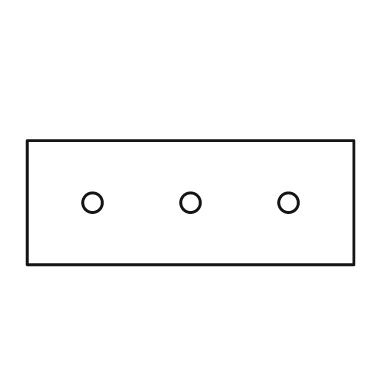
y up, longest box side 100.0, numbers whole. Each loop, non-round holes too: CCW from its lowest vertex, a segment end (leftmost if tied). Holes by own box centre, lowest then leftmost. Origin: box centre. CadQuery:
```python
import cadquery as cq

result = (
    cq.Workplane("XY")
    .moveTo(-50.0, -19.0)
    .lineTo(50.0, -19.0)
    .lineTo(50.0, 19.0)
    .lineTo(-50.0, 19.0)
    .close()
    .moveTo(-30.0, 0.0)
    .circle(3.0)
    .moveTo(0.0, 0.0)
    .circle(3.0)
    .moveTo(30.0, 0.0)
    .circle(3.0)
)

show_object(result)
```